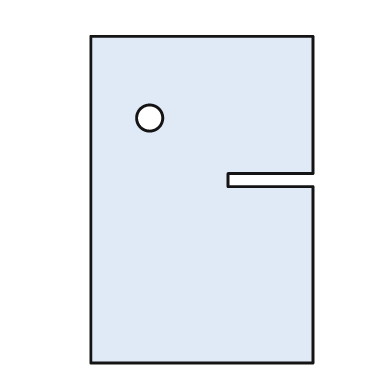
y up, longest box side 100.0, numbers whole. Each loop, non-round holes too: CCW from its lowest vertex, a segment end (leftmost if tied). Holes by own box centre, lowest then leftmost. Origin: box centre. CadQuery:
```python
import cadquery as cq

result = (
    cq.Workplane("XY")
    .moveTo(-34.0, -50.0)
    .lineTo(34.0, -50.0)
    .lineTo(34.0, 4.0)
    .lineTo(8.0, 4.0)
    .lineTo(8.0, 8.0)
    .lineTo(34.0, 8.0)
    .lineTo(34.0, 50.0)
    .lineTo(-34.0, 50.0)
    .close()
    .moveTo(-16.0, 25.0)
    .circle(4.0)
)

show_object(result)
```